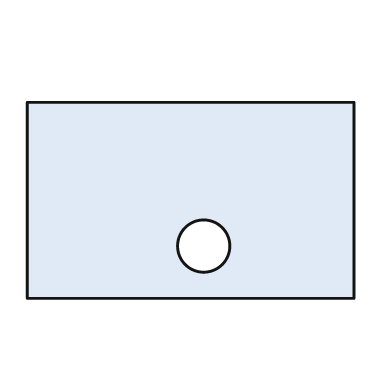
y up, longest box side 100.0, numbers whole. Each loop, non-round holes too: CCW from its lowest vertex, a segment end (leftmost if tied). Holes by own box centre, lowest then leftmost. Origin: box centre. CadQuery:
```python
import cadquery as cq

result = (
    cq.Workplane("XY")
    .moveTo(-50.0, -30.0)
    .lineTo(50.0, -30.0)
    .lineTo(50.0, 30.0)
    .lineTo(-50.0, 30.0)
    .close()
    .moveTo(4.0, -14.0)
    .circle(8.0)
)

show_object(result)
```